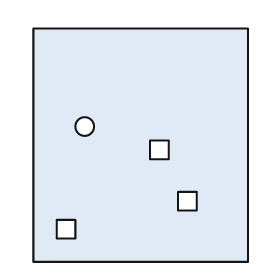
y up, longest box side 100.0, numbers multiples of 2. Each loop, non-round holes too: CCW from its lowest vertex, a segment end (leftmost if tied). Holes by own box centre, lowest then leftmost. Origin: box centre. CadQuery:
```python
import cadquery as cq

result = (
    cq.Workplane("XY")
    .moveTo(-46.0, -50.0)
    .lineTo(46.0, -50.0)
    .lineTo(46.0, 50.0)
    .lineTo(-46.0, 50.0)
    .close()
    .moveTo(-36.0, -40.0)
    .lineTo(-28.0, -40.0)
    .lineTo(-28.0, -32.0)
    .lineTo(-36.0, -32.0)
    .close()
    .moveTo(16.0, -28.0)
    .lineTo(24.0, -28.0)
    .lineTo(24.0, -20.0)
    .lineTo(16.0, -20.0)
    .close()
    .moveTo(4.0, -6.0)
    .lineTo(12.0, -6.0)
    .lineTo(12.0, 2.0)
    .lineTo(4.0, 2.0)
    .close()
    .moveTo(-24.0, 8.0)
    .circle(4.0)
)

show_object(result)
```